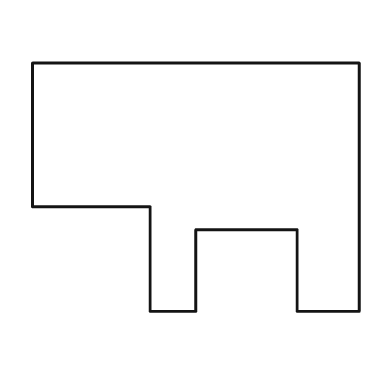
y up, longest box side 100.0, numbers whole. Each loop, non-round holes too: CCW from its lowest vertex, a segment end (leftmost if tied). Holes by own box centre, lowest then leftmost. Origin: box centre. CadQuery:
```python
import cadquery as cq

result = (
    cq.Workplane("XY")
    .moveTo(-14.0, -38.0)
    .lineTo(0.0, -38.0)
    .lineTo(0.0, -13.0)
    .lineTo(31.0, -13.0)
    .lineTo(31.0, -38.0)
    .lineTo(50.0, -38.0)
    .lineTo(50.0, 38.0)
    .lineTo(-50.0, 38.0)
    .lineTo(-50.0, -6.0)
    .lineTo(-14.0, -6.0)
    .close()
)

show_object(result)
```